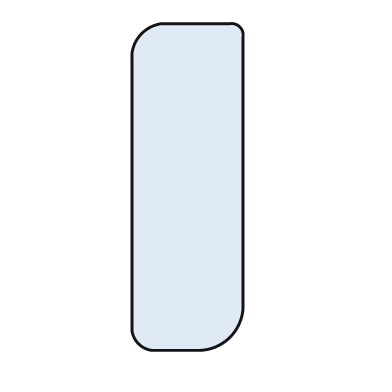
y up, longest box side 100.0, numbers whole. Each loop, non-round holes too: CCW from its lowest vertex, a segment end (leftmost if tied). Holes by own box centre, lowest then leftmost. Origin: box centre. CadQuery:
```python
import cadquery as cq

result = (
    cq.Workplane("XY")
    .moveTo(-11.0, -50.0)
    .lineTo(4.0, -50.0)
    .threePointArc((13.0, -46.0), (17.0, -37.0))
    .lineTo(17.0, 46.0)
    .threePointArc((16.0, 49.0), (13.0, 50.0))
    .lineTo(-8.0, 50.0)
    .threePointArc((-14.0, 47.0), (-17.0, 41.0))
    .lineTo(-17.0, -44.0)
    .threePointArc((-15.0, -48.0), (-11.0, -50.0))
    .close()
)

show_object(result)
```